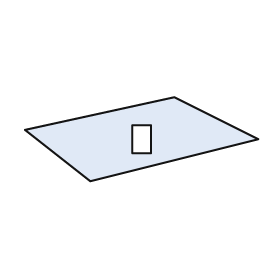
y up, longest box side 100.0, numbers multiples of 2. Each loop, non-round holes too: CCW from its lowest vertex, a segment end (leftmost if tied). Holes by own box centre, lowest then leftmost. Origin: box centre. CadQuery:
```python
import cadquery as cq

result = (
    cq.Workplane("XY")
    .moveTo(-22.0, -18.0)
    .lineTo(50.0, 0.0)
    .lineTo(14.0, 18.0)
    .lineTo(-50.0, 4.0)
    .close()
    .moveTo(-4.0, -6.0)
    .lineTo(4.0, -6.0)
    .lineTo(4.0, 6.0)
    .lineTo(-4.0, 6.0)
    .close()
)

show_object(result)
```